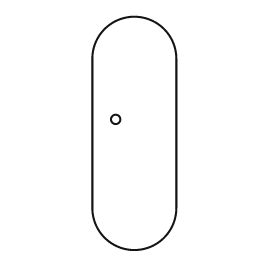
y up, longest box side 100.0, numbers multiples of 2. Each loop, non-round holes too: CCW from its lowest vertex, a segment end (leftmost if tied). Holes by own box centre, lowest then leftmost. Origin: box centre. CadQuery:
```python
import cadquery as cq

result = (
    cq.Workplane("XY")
    .moveTo(-18.0, -32.0)
    .threePointArc((0.0, -50.0), (18.0, -32.0))
    .lineTo(18.0, 32.0)
    .threePointArc((0.0, 50.0), (-18.0, 32.0))
    .close()
    .moveTo(-8.0, 6.0)
    .circle(2.0)
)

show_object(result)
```